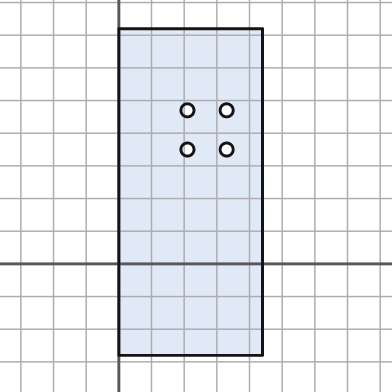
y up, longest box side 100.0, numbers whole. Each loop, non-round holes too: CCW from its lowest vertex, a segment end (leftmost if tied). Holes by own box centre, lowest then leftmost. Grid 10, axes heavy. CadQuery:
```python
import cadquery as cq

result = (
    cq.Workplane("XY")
    .moveTo(0.0, -28.0)
    .lineTo(44.0, -28.0)
    .lineTo(44.0, 72.0)
    .lineTo(0.0, 72.0)
    .close()
    .moveTo(21.0, 35.0)
    .circle(2.0)
    .moveTo(33.0, 35.0)
    .circle(2.0)
    .moveTo(21.0, 47.0)
    .circle(2.0)
    .moveTo(33.0, 47.0)
    .circle(2.0)
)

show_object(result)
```